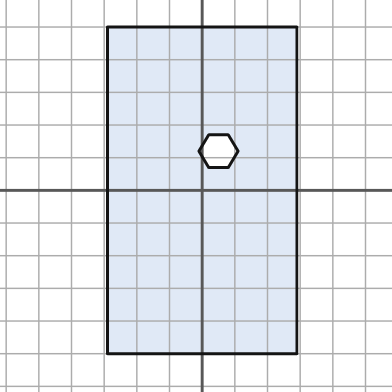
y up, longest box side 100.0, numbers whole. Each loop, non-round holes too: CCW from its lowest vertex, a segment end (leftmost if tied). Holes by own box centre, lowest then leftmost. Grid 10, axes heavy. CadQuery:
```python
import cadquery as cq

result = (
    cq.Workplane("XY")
    .moveTo(-29.0, -50.0)
    .lineTo(29.0, -50.0)
    .lineTo(29.0, 50.0)
    .lineTo(-29.0, 50.0)
    .close()
    .moveTo(2.0, 7.0)
    .lineTo(8.0, 7.0)
    .lineTo(11.0, 12.0)
    .lineTo(8.0, 17.0)
    .lineTo(2.0, 17.0)
    .lineTo(-1.0, 12.0)
    .close()
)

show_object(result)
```